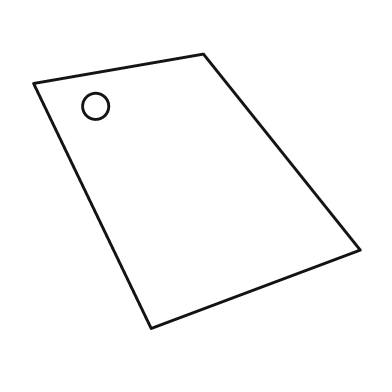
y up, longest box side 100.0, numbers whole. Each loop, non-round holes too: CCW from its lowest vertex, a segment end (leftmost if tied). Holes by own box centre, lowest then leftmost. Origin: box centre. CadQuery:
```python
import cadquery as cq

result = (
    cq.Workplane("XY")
    .moveTo(-14.0, -42.0)
    .lineTo(50.0, -18.0)
    .lineTo(2.0, 42.0)
    .lineTo(-50.0, 33.0)
    .close()
    .moveTo(-31.0, 26.0)
    .circle(4.0)
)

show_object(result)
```